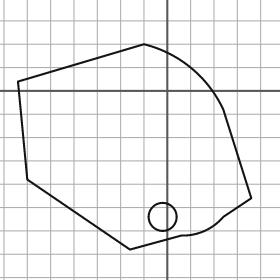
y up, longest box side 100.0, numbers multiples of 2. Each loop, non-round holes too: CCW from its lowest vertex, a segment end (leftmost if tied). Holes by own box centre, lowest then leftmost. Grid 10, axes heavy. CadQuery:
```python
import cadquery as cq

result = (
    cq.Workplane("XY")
    .moveTo(-16.0, -68.0)
    .lineTo(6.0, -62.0)
    .threePointArc((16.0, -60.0), (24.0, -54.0))
    .lineTo(36.0, -46.0)
    .lineTo(24.0, -8.0)
    .threePointArc((10.0, 10.0), (-10.0, 20.0))
    .lineTo(-64.0, 4.0)
    .lineTo(-60.0, -38.0)
    .close()
    .moveTo(-2.0, -54.0)
    .circle(6.0)
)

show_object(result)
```